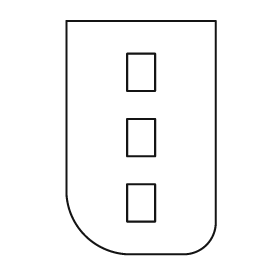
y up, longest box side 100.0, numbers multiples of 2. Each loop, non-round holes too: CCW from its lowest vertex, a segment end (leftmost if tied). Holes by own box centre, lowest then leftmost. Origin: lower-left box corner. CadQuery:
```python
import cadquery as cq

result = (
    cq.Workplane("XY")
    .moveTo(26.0, 0.0)
    .lineTo(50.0, 0.0)
    .threePointArc((60.0, 4.0), (64.0, 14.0))
    .lineTo(64.0, 100.0)
    .lineTo(0.0, 100.0)
    .lineTo(0.0, 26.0)
    .threePointArc((8.0, 8.0), (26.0, 0.0))
    .close()
    .moveTo(26.0, 14.0)
    .lineTo(38.0, 14.0)
    .lineTo(38.0, 30.0)
    .lineTo(26.0, 30.0)
    .close()
    .moveTo(26.0, 42.0)
    .lineTo(38.0, 42.0)
    .lineTo(38.0, 58.0)
    .lineTo(26.0, 58.0)
    .close()
    .moveTo(26.0, 70.0)
    .lineTo(38.0, 70.0)
    .lineTo(38.0, 86.0)
    .lineTo(26.0, 86.0)
    .close()
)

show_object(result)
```